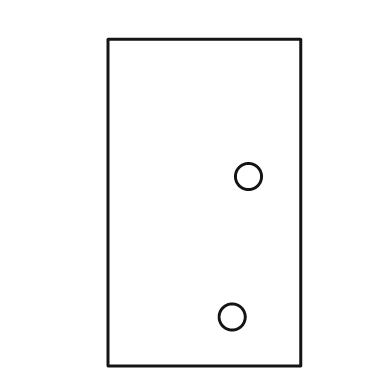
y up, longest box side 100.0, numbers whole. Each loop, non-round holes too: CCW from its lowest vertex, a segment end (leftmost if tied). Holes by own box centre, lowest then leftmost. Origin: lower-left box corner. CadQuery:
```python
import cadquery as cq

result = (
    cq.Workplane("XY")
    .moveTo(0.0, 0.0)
    .lineTo(59.0, 0.0)
    .lineTo(59.0, 100.0)
    .lineTo(0.0, 100.0)
    .close()
    .moveTo(38.0, 15.0)
    .circle(4.0)
    .moveTo(43.0, 58.0)
    .circle(4.0)
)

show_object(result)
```